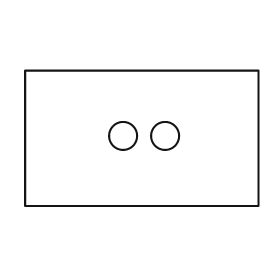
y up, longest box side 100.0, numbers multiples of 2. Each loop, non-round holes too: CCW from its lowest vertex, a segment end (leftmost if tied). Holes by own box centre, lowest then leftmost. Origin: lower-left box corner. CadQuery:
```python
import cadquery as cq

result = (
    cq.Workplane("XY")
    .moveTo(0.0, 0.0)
    .lineTo(100.0, 0.0)
    .lineTo(100.0, 58.0)
    .lineTo(0.0, 58.0)
    .close()
    .moveTo(42.0, 30.0)
    .circle(6.0)
    .moveTo(60.0, 30.0)
    .circle(6.0)
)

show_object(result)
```